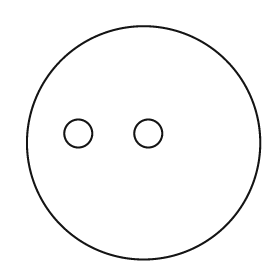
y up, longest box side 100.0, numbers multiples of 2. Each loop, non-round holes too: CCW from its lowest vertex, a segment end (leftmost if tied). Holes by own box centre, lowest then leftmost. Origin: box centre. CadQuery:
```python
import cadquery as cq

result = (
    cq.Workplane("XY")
    .moveTo(0.0, 0.0)
    .circle(50.0)
    .moveTo(-28.0, 4.0)
    .circle(6.0)
    .moveTo(2.0, 4.0)
    .circle(6.0)
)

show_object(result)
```